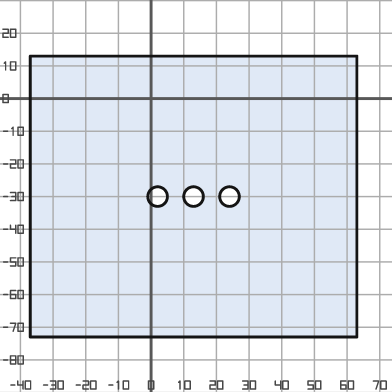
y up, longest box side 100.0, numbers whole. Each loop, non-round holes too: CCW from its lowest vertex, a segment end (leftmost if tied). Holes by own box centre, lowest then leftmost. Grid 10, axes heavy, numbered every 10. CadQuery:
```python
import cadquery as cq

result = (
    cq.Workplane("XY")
    .moveTo(-37.0, -73.0)
    .lineTo(63.0, -73.0)
    .lineTo(63.0, 13.0)
    .lineTo(-37.0, 13.0)
    .close()
    .moveTo(2.0, -30.0)
    .circle(3.0)
    .moveTo(13.0, -30.0)
    .circle(3.0)
    .moveTo(24.0, -30.0)
    .circle(3.0)
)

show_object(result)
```